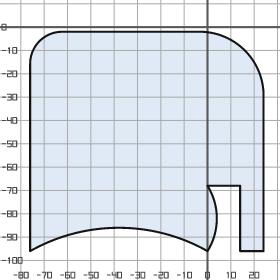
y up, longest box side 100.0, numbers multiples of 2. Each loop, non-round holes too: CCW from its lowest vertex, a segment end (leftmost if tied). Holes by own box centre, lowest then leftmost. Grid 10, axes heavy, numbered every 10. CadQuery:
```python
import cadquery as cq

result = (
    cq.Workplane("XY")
    .moveTo(-76.0, -96.0)
    .threePointArc((-38.0, -86.0), (0.0, -96.0))
    .threePointArc((4.0, -82.0), (0.0, -68.0))
    .lineTo(14.0, -68.0)
    .lineTo(14.0, -96.0)
    .lineTo(24.0, -96.0)
    .lineTo(24.0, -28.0)
    .threePointArc((16.0, -10.0), (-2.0, -2.0))
    .lineTo(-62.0, -2.0)
    .threePointArc((-72.0, -6.0), (-76.0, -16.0))
    .close()
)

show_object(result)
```